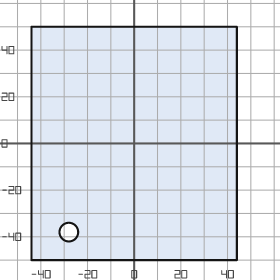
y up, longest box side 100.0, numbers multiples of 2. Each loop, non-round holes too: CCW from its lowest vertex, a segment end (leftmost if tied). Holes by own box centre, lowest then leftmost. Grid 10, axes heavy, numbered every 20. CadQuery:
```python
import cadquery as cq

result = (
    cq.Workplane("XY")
    .moveTo(-44.0, -50.0)
    .lineTo(44.0, -50.0)
    .lineTo(44.0, 50.0)
    .lineTo(-44.0, 50.0)
    .close()
    .moveTo(-28.0, -38.0)
    .circle(4.0)
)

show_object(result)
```